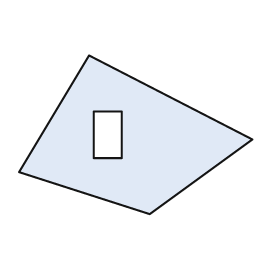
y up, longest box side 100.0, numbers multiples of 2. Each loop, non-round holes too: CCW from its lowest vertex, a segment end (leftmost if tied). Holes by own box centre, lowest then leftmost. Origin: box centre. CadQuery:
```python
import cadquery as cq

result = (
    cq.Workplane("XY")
    .moveTo(6.0, -34.0)
    .lineTo(50.0, -2.0)
    .lineTo(-20.0, 34.0)
    .lineTo(-50.0, -16.0)
    .close()
    .moveTo(-18.0, -10.0)
    .lineTo(-6.0, -10.0)
    .lineTo(-6.0, 10.0)
    .lineTo(-18.0, 10.0)
    .close()
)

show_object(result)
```